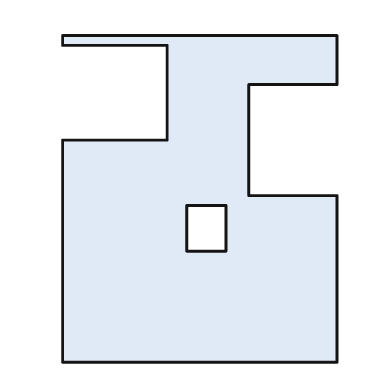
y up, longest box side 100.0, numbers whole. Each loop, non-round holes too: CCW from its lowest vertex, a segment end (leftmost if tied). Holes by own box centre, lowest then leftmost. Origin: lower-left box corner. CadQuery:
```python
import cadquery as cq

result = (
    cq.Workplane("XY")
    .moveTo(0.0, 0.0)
    .lineTo(84.0, 0.0)
    .lineTo(84.0, 51.0)
    .lineTo(57.0, 51.0)
    .lineTo(57.0, 85.0)
    .lineTo(84.0, 85.0)
    .lineTo(84.0, 100.0)
    .lineTo(0.0, 100.0)
    .lineTo(0.0, 97.0)
    .lineTo(32.0, 97.0)
    .lineTo(32.0, 68.0)
    .lineTo(0.0, 68.0)
    .close()
    .moveTo(38.0, 34.0)
    .lineTo(50.0, 34.0)
    .lineTo(50.0, 48.0)
    .lineTo(38.0, 48.0)
    .close()
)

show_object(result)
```